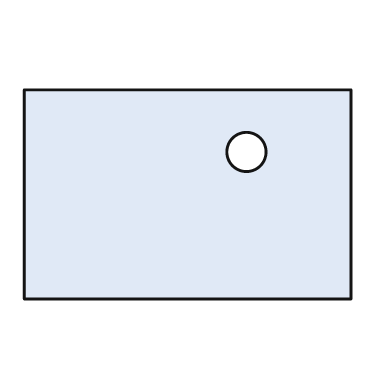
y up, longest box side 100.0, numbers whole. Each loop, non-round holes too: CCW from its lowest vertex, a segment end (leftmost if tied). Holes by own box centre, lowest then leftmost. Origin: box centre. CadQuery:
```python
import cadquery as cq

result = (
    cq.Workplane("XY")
    .moveTo(-50.0, -32.0)
    .lineTo(50.0, -32.0)
    .lineTo(50.0, 32.0)
    .lineTo(-50.0, 32.0)
    .close()
    .moveTo(18.0, 13.0)
    .circle(6.0)
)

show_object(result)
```